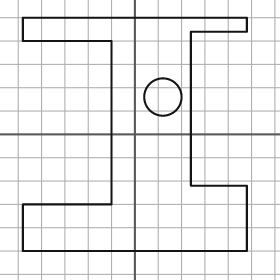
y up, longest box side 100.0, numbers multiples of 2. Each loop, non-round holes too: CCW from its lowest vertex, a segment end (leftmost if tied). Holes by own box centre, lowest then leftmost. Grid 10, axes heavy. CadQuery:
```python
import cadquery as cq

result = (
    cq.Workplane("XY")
    .moveTo(-48.0, -50.0)
    .lineTo(48.0, -50.0)
    .lineTo(48.0, -22.0)
    .lineTo(24.0, -22.0)
    .lineTo(24.0, 44.0)
    .lineTo(48.0, 44.0)
    .lineTo(48.0, 50.0)
    .lineTo(-48.0, 50.0)
    .lineTo(-48.0, 40.0)
    .lineTo(-10.0, 40.0)
    .lineTo(-10.0, -30.0)
    .lineTo(-48.0, -30.0)
    .close()
    .moveTo(12.0, 16.0)
    .circle(8.0)
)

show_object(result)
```